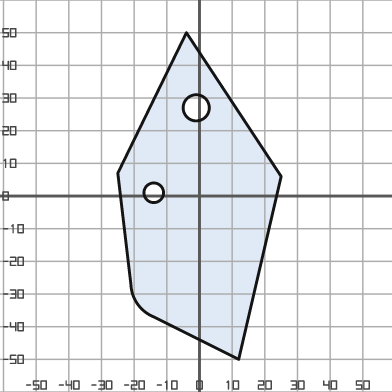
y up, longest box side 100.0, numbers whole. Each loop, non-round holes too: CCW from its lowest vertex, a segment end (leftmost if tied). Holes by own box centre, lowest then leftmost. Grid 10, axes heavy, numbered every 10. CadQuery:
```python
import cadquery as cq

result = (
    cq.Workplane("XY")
    .moveTo(12.0, -50.0)
    .lineTo(25.0, 6.0)
    .lineTo(-4.0, 50.0)
    .lineTo(-25.0, 7.0)
    .lineTo(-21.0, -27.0)
    .threePointArc((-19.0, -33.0), (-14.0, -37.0))
    .close()
    .moveTo(-14.0, 1.0)
    .circle(3.0)
    .moveTo(-1.0, 27.0)
    .circle(4.0)
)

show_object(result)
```